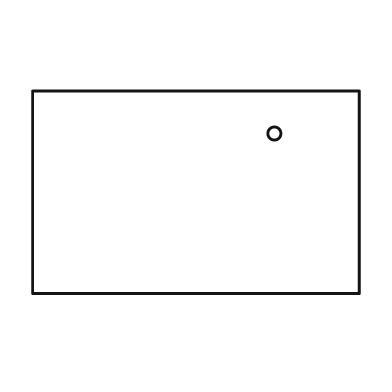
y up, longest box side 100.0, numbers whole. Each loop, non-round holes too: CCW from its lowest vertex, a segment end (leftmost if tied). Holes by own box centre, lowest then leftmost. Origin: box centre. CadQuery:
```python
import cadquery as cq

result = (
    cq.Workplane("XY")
    .moveTo(-50.0, -31.0)
    .lineTo(50.0, -31.0)
    .lineTo(50.0, 31.0)
    .lineTo(-50.0, 31.0)
    .close()
    .moveTo(24.0, 18.0)
    .circle(2.0)
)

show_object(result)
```